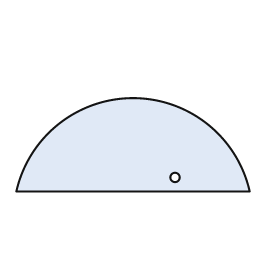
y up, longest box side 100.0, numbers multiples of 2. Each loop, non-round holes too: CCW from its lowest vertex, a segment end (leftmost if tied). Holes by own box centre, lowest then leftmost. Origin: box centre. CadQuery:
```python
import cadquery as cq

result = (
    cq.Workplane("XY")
    .moveTo(-50.0, -20.0)
    .lineTo(50.0, -20.0)
    .threePointArc((0.0, 20.0), (-50.0, -20.0))
    .close()
    .moveTo(18.0, -14.0)
    .circle(2.0)
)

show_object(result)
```